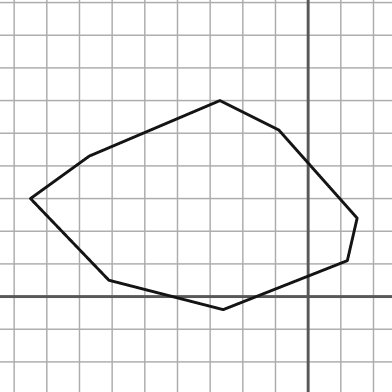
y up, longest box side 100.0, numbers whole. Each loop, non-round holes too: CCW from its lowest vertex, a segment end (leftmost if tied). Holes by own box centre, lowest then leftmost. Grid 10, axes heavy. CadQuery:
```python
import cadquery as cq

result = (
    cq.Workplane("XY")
    .moveTo(-26.0, -4.0)
    .lineTo(12.0, 11.0)
    .lineTo(15.0, 24.0)
    .lineTo(-9.0, 51.0)
    .lineTo(-27.0, 60.0)
    .lineTo(-67.0, 43.0)
    .lineTo(-85.0, 30.0)
    .lineTo(-61.0, 5.0)
    .close()
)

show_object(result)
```